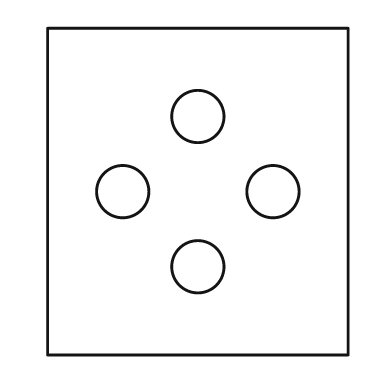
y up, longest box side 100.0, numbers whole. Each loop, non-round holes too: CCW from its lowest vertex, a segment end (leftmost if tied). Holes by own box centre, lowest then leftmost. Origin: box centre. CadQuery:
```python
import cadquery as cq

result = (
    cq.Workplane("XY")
    .moveTo(-46.0, -50.0)
    .lineTo(46.0, -50.0)
    .lineTo(46.0, 50.0)
    .lineTo(-46.0, 50.0)
    .close()
    .moveTo(0.0, -23.0)
    .circle(8.0)
    .moveTo(-23.0, 0.0)
    .circle(8.0)
    .moveTo(23.0, 0.0)
    .circle(8.0)
    .moveTo(0.0, 23.0)
    .circle(8.0)
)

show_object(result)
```